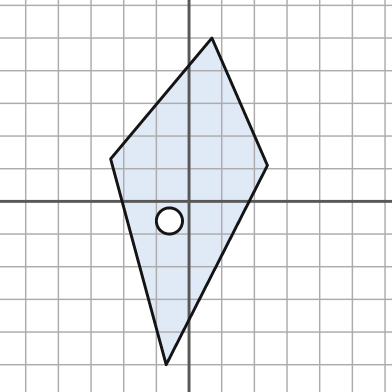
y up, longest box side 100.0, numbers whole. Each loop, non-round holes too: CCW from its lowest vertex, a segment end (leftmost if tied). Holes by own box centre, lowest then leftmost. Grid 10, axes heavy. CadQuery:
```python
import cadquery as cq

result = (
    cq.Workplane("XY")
    .moveTo(-7.0, -50.0)
    .lineTo(24.0, 11.0)
    .lineTo(7.0, 50.0)
    .lineTo(-24.0, 13.0)
    .close()
    .moveTo(-6.0, -6.0)
    .circle(4.0)
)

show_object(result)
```